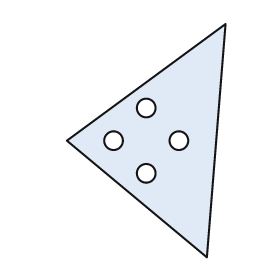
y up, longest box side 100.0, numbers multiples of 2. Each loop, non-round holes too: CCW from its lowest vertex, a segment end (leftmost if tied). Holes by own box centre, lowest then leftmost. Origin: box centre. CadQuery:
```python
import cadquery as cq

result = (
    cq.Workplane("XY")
    .moveTo(26.0, -50.0)
    .lineTo(34.0, 50.0)
    .lineTo(-34.0, 0.0)
    .close()
    .moveTo(0.0, -14.0)
    .circle(4.0)
    .moveTo(-14.0, 0.0)
    .circle(4.0)
    .moveTo(14.0, 0.0)
    .circle(4.0)
    .moveTo(0.0, 14.0)
    .circle(4.0)
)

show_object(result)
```